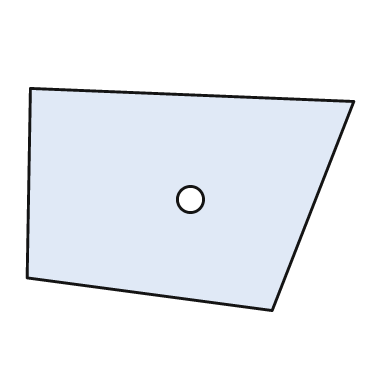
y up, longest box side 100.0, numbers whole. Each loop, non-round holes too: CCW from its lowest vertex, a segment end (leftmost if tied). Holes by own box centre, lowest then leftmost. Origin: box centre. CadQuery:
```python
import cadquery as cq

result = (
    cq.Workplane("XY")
    .moveTo(25.0, -34.0)
    .lineTo(50.0, 30.0)
    .lineTo(-49.0, 34.0)
    .lineTo(-50.0, -24.0)
    .close()
    .moveTo(0.0, 0.0)
    .circle(4.0)
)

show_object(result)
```